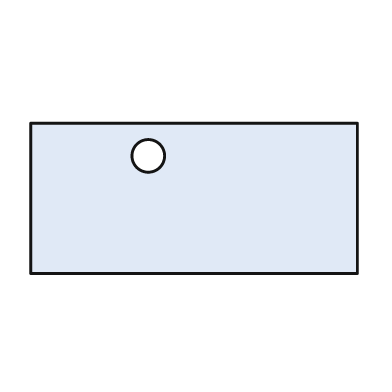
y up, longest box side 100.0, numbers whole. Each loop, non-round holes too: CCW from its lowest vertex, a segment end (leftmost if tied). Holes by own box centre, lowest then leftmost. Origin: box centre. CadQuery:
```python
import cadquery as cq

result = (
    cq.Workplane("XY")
    .moveTo(-50.0, -23.0)
    .lineTo(50.0, -23.0)
    .lineTo(50.0, 23.0)
    .lineTo(-50.0, 23.0)
    .close()
    .moveTo(-14.0, 13.0)
    .circle(5.0)
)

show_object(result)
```